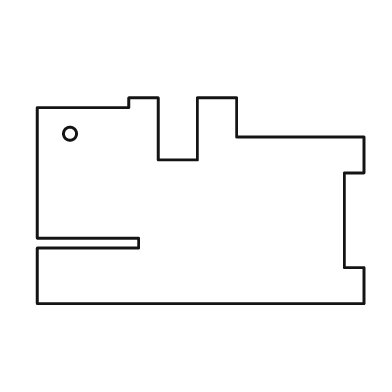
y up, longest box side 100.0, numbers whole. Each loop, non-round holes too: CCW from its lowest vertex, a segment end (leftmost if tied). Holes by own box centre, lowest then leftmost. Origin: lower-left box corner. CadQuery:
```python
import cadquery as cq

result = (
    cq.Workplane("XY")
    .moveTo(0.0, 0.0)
    .lineTo(100.0, 0.0)
    .lineTo(100.0, 11.0)
    .lineTo(94.0, 11.0)
    .lineTo(94.0, 40.0)
    .lineTo(100.0, 40.0)
    .lineTo(100.0, 51.0)
    .lineTo(61.0, 51.0)
    .lineTo(61.0, 63.0)
    .lineTo(49.0, 63.0)
    .lineTo(49.0, 44.0)
    .lineTo(37.0, 44.0)
    .lineTo(37.0, 63.0)
    .lineTo(28.0, 63.0)
    .lineTo(28.0, 60.0)
    .lineTo(0.0, 60.0)
    .lineTo(0.0, 20.0)
    .lineTo(31.0, 20.0)
    .lineTo(31.0, 17.0)
    .lineTo(0.0, 17.0)
    .close()
    .moveTo(10.0, 52.0)
    .circle(2.0)
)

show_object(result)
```